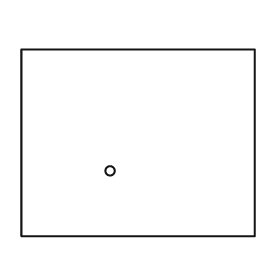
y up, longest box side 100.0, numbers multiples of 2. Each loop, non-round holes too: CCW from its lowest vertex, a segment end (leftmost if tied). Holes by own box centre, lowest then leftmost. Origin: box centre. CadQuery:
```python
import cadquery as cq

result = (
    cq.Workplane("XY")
    .moveTo(-50.0, -40.0)
    .lineTo(50.0, -40.0)
    .lineTo(50.0, 40.0)
    .lineTo(-50.0, 40.0)
    .close()
    .moveTo(-12.0, -12.0)
    .circle(2.0)
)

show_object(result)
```